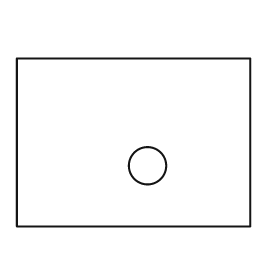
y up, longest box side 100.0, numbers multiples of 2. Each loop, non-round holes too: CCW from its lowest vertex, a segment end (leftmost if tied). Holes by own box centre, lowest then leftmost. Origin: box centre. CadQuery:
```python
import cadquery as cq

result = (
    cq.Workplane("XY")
    .moveTo(-50.0, -36.0)
    .lineTo(50.0, -36.0)
    .lineTo(50.0, 36.0)
    .lineTo(-50.0, 36.0)
    .close()
    .moveTo(6.0, -10.0)
    .circle(8.0)
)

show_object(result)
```